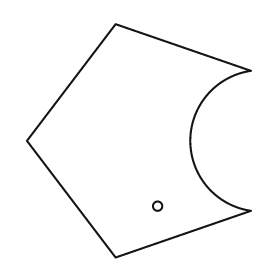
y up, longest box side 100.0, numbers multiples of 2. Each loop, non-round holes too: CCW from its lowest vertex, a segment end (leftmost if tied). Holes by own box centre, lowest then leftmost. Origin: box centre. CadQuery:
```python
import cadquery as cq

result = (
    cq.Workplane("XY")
    .moveTo(-10.0, -50.0)
    .lineTo(48.0, -30.0)
    .threePointArc((22.0, 0.0), (48.0, 30.0))
    .lineTo(-10.0, 50.0)
    .lineTo(-48.0, 0.0)
    .close()
    .moveTo(8.0, -28.0)
    .circle(2.0)
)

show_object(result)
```